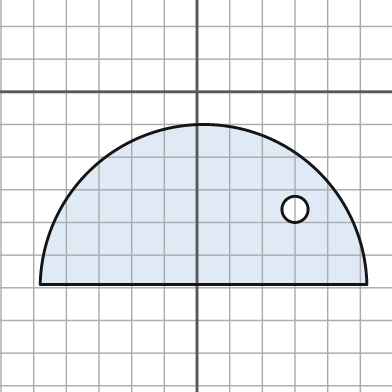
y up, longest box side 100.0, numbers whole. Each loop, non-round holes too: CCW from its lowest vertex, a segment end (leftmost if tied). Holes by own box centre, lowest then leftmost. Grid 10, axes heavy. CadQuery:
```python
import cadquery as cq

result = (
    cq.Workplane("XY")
    .moveTo(-48.0, -59.0)
    .lineTo(52.0, -59.0)
    .threePointArc((2.0, -10.0), (-48.0, -59.0))
    .close()
    .moveTo(30.0, -36.0)
    .circle(4.0)
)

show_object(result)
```